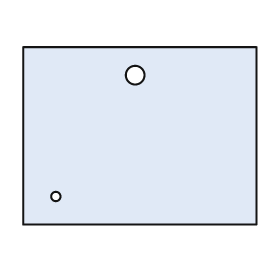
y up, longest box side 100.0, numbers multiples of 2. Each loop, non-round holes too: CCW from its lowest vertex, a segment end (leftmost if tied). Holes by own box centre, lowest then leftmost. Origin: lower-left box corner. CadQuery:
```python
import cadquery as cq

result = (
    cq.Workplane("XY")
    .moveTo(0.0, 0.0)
    .lineTo(100.0, 0.0)
    .lineTo(100.0, 76.0)
    .lineTo(0.0, 76.0)
    .close()
    .moveTo(14.0, 12.0)
    .circle(2.0)
    .moveTo(48.0, 64.0)
    .circle(4.0)
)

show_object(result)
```